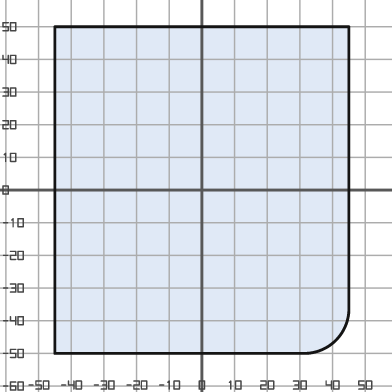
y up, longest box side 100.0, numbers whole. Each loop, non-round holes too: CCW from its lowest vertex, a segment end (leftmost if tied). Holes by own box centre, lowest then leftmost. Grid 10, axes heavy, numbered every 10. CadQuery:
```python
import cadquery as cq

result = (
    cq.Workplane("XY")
    .moveTo(-45.0, -50.0)
    .lineTo(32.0, -50.0)
    .threePointArc((41.0, -46.0), (45.0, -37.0))
    .lineTo(45.0, 50.0)
    .lineTo(-45.0, 50.0)
    .close()
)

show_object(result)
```